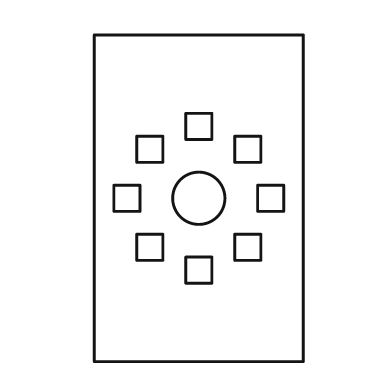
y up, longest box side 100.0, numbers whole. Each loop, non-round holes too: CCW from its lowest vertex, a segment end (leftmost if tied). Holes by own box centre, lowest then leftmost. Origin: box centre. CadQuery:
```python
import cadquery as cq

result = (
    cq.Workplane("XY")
    .moveTo(-32.0, -50.0)
    .lineTo(32.0, -50.0)
    .lineTo(32.0, 50.0)
    .lineTo(-32.0, 50.0)
    .close()
    .moveTo(-4.0, -26.0)
    .lineTo(4.0, -26.0)
    .lineTo(4.0, -18.0)
    .lineTo(-4.0, -18.0)
    .close()
    .moveTo(-19.0, -19.0)
    .lineTo(-11.0, -19.0)
    .lineTo(-11.0, -11.0)
    .lineTo(-19.0, -11.0)
    .close()
    .moveTo(11.0, -19.0)
    .lineTo(19.0, -19.0)
    .lineTo(19.0, -11.0)
    .lineTo(11.0, -11.0)
    .close()
    .moveTo(-26.0, -4.0)
    .lineTo(-18.0, -4.0)
    .lineTo(-18.0, 4.0)
    .lineTo(-26.0, 4.0)
    .close()
    .moveTo(0.0, 0.0)
    .circle(8.0)
    .moveTo(18.0, -4.0)
    .lineTo(26.0, -4.0)
    .lineTo(26.0, 4.0)
    .lineTo(18.0, 4.0)
    .close()
    .moveTo(-19.0, 11.0)
    .lineTo(-11.0, 11.0)
    .lineTo(-11.0, 19.0)
    .lineTo(-19.0, 19.0)
    .close()
    .moveTo(11.0, 11.0)
    .lineTo(19.0, 11.0)
    .lineTo(19.0, 19.0)
    .lineTo(11.0, 19.0)
    .close()
    .moveTo(-4.0, 18.0)
    .lineTo(4.0, 18.0)
    .lineTo(4.0, 26.0)
    .lineTo(-4.0, 26.0)
    .close()
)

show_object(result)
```